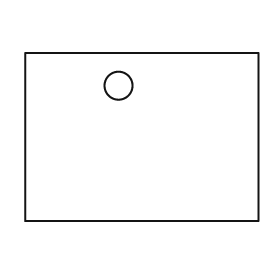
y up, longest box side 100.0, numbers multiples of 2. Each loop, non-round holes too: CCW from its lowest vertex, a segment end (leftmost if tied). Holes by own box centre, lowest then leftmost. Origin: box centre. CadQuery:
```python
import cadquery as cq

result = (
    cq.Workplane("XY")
    .moveTo(-50.0, -36.0)
    .lineTo(50.0, -36.0)
    .lineTo(50.0, 36.0)
    .lineTo(-50.0, 36.0)
    .close()
    .moveTo(-10.0, 22.0)
    .circle(6.0)
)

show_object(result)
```